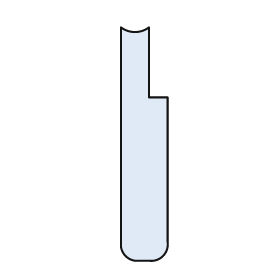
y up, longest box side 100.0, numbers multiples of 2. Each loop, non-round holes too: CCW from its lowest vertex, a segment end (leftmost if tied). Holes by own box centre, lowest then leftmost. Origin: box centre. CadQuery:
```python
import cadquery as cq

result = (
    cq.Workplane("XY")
    .moveTo(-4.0, -50.0)
    .lineTo(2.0, -50.0)
    .threePointArc((8.0, -48.0), (10.0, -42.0))
    .lineTo(10.0, 20.0)
    .lineTo(2.0, 20.0)
    .lineTo(2.0, 50.0)
    .threePointArc((-4.0, 48.0), (-10.0, 50.0))
    .lineTo(-10.0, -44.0)
    .threePointArc((-8.0, -48.0), (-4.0, -50.0))
    .close()
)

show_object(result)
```